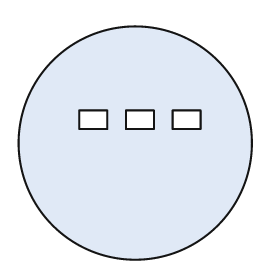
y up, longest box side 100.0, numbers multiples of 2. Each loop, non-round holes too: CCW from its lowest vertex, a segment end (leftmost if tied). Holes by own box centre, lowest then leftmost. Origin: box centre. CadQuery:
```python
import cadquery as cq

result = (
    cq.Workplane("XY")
    .moveTo(0.0, 0.0)
    .circle(50.0)
    .moveTo(-24.0, 6.0)
    .lineTo(-12.0, 6.0)
    .lineTo(-12.0, 14.0)
    .lineTo(-24.0, 14.0)
    .close()
    .moveTo(-4.0, 6.0)
    .lineTo(8.0, 6.0)
    .lineTo(8.0, 14.0)
    .lineTo(-4.0, 14.0)
    .close()
    .moveTo(16.0, 6.0)
    .lineTo(28.0, 6.0)
    .lineTo(28.0, 14.0)
    .lineTo(16.0, 14.0)
    .close()
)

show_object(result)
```